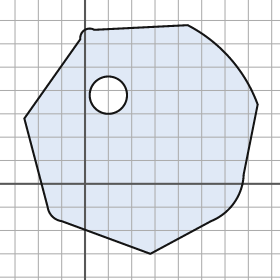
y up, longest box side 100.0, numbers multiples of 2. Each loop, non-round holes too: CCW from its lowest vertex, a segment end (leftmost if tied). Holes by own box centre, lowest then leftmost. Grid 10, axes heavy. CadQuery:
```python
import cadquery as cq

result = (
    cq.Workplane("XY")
    .moveTo(28.0, -30.0)
    .lineTo(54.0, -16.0)
    .threePointArc((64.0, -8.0), (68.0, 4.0))
    .lineTo(74.0, 34.0)
    .threePointArc((62.0, 54.0), (44.0, 68.0))
    .lineTo(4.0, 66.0)
    .threePointArc((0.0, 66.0), (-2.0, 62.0))
    .lineTo(-26.0, 28.0)
    .lineTo(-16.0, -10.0)
    .threePointArc((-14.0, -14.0), (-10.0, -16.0))
    .close()
    .moveTo(10.0, 38.0)
    .circle(8.0)
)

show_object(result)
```